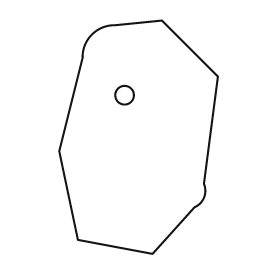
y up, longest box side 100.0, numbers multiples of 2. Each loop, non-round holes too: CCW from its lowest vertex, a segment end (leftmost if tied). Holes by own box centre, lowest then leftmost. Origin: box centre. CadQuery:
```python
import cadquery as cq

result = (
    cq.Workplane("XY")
    .moveTo(6.0, -50.0)
    .lineTo(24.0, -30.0)
    .threePointArc((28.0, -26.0), (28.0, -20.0))
    .lineTo(34.0, 26.0)
    .lineTo(10.0, 50.0)
    .lineTo(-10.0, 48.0)
    .threePointArc((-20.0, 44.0), (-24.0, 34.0))
    .lineTo(-34.0, -6.0)
    .lineTo(-26.0, -44.0)
    .close()
    .moveTo(-6.0, 18.0)
    .circle(4.0)
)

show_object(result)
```